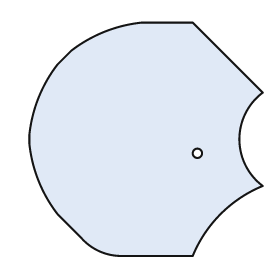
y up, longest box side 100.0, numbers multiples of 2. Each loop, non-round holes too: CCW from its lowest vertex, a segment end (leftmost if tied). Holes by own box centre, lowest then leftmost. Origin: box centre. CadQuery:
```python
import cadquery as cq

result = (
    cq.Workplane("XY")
    .moveTo(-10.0, -50.0)
    .lineTo(20.0, -50.0)
    .threePointArc((32.0, -32.0), (50.0, -20.0))
    .threePointArc((40.0, 0.0), (50.0, 20.0))
    .lineTo(20.0, 50.0)
    .lineTo(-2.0, 50.0)
    .threePointArc((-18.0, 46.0), (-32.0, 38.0))
    .lineTo(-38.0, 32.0)
    .threePointArc((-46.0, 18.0), (-50.0, 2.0))
    .lineTo(-50.0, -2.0)
    .threePointArc((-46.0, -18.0), (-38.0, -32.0))
    .lineTo(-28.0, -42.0)
    .threePointArc((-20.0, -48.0), (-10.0, -50.0))
    .close()
    .moveTo(22.0, -6.0)
    .circle(2.0)
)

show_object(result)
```